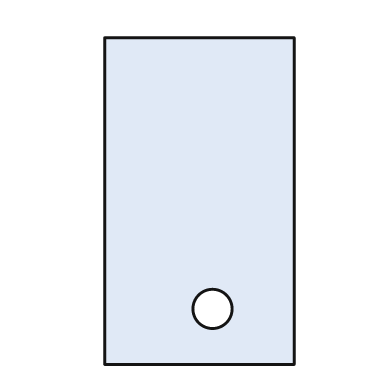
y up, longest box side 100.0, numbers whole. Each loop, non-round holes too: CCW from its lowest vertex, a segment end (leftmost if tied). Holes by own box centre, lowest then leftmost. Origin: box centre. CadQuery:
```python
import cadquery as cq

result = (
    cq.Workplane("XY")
    .moveTo(-29.0, -50.0)
    .lineTo(29.0, -50.0)
    .lineTo(29.0, 50.0)
    .lineTo(-29.0, 50.0)
    .close()
    .moveTo(4.0, -33.0)
    .circle(6.0)
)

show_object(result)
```